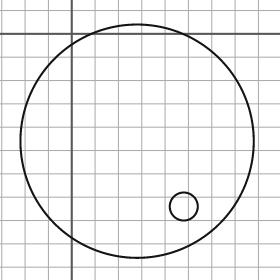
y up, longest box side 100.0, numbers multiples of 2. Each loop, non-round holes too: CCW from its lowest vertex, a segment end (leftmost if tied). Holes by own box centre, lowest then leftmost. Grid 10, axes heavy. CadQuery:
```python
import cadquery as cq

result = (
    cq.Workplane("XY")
    .moveTo(28.0, -46.0)
    .circle(50.0)
    .moveTo(48.0, -74.0)
    .circle(6.0)
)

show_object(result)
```